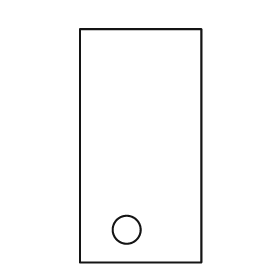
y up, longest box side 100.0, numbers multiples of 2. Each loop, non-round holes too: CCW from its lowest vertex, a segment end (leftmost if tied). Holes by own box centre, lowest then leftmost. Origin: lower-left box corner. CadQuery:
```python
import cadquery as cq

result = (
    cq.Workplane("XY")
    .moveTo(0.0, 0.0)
    .lineTo(52.0, 0.0)
    .lineTo(52.0, 100.0)
    .lineTo(0.0, 100.0)
    .close()
    .moveTo(20.0, 14.0)
    .circle(6.0)
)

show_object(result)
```